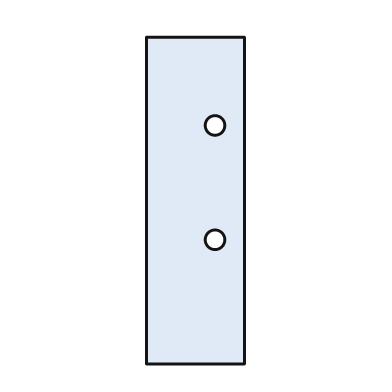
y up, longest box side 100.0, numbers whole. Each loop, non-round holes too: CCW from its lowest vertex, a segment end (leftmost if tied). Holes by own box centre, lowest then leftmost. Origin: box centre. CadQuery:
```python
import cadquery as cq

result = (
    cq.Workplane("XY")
    .moveTo(-15.0, -50.0)
    .lineTo(15.0, -50.0)
    .lineTo(15.0, 50.0)
    .lineTo(-15.0, 50.0)
    .close()
    .moveTo(6.0, -12.0)
    .circle(3.0)
    .moveTo(6.0, 23.0)
    .circle(3.0)
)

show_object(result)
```